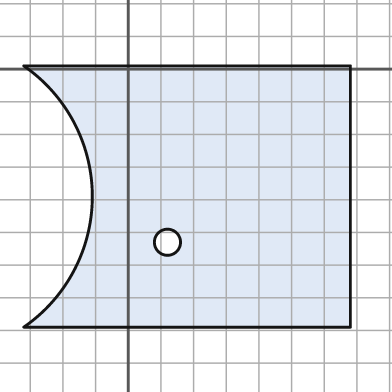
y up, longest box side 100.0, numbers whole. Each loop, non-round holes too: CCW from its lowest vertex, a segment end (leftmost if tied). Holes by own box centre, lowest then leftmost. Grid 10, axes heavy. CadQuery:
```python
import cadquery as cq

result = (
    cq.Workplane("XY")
    .moveTo(-32.0, -79.0)
    .lineTo(68.0, -79.0)
    .lineTo(68.0, 1.0)
    .lineTo(-32.0, 1.0)
    .threePointArc((-11.0, -39.0), (-32.0, -79.0))
    .close()
    .moveTo(12.0, -53.0)
    .circle(4.0)
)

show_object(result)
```